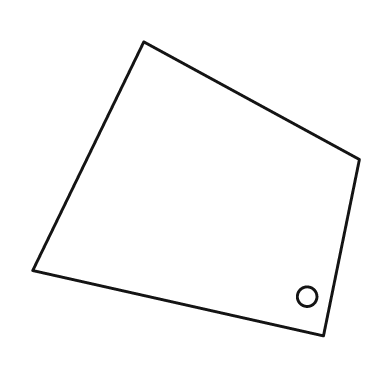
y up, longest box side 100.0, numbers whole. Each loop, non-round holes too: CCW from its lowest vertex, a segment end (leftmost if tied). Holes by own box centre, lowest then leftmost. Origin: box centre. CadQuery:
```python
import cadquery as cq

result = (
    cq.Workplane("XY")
    .moveTo(39.0, -45.0)
    .lineTo(50.0, 9.0)
    .lineTo(-16.0, 45.0)
    .lineTo(-50.0, -25.0)
    .close()
    .moveTo(34.0, -33.0)
    .circle(3.0)
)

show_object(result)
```